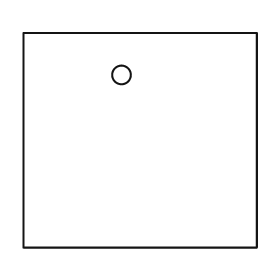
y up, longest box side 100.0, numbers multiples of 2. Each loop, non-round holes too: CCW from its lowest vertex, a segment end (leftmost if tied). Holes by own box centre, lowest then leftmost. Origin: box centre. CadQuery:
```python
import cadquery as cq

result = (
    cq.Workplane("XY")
    .moveTo(-50.0, -46.0)
    .lineTo(50.0, -46.0)
    .lineTo(50.0, 46.0)
    .lineTo(-50.0, 46.0)
    .close()
    .moveTo(-8.0, 28.0)
    .circle(4.0)
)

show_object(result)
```